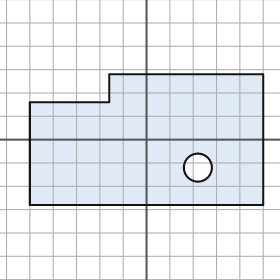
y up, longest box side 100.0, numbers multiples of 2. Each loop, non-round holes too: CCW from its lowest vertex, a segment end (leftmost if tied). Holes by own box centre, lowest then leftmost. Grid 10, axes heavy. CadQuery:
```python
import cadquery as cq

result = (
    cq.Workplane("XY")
    .moveTo(-50.0, -28.0)
    .lineTo(50.0, -28.0)
    .lineTo(50.0, 28.0)
    .lineTo(-16.0, 28.0)
    .lineTo(-16.0, 16.0)
    .lineTo(-50.0, 16.0)
    .close()
    .moveTo(22.0, -12.0)
    .circle(6.0)
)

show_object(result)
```